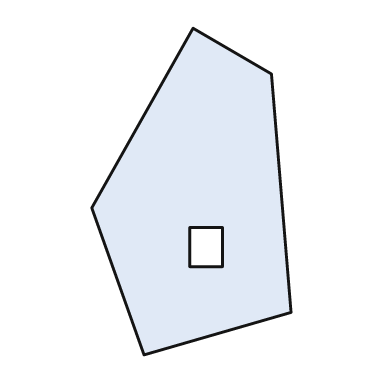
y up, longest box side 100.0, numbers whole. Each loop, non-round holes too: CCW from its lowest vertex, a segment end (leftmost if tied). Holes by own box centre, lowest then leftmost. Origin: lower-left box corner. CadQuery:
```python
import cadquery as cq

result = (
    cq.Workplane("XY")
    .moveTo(16.0, 0.0)
    .lineTo(61.0, 13.0)
    .lineTo(55.0, 86.0)
    .lineTo(31.0, 100.0)
    .lineTo(0.0, 45.0)
    .close()
    .moveTo(30.0, 27.0)
    .lineTo(40.0, 27.0)
    .lineTo(40.0, 39.0)
    .lineTo(30.0, 39.0)
    .close()
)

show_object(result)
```